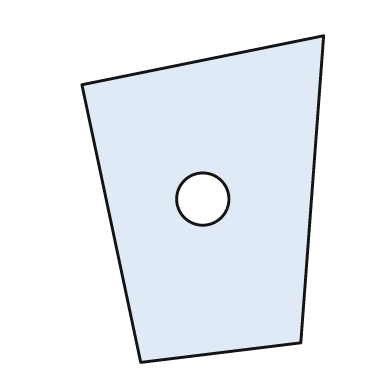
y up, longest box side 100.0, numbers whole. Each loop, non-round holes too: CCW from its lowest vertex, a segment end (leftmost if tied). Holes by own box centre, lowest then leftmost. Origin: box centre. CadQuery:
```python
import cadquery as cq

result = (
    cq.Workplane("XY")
    .moveTo(-19.0, -50.0)
    .lineTo(30.0, -44.0)
    .lineTo(37.0, 50.0)
    .lineTo(-37.0, 35.0)
    .close()
    .moveTo(0.0, 0.0)
    .circle(8.0)
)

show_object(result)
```